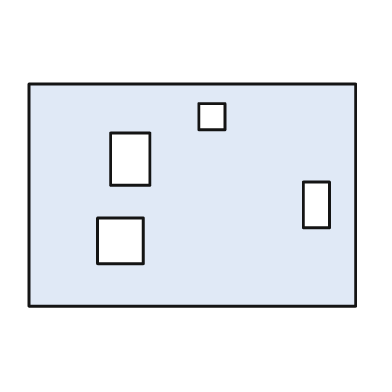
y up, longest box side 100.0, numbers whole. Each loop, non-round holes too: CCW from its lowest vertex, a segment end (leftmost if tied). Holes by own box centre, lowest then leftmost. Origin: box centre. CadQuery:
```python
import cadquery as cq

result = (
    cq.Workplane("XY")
    .moveTo(-50.0, -34.0)
    .lineTo(50.0, -34.0)
    .lineTo(50.0, 34.0)
    .lineTo(-50.0, 34.0)
    .close()
    .moveTo(-29.0, -21.0)
    .lineTo(-15.0, -21.0)
    .lineTo(-15.0, -7.0)
    .lineTo(-29.0, -7.0)
    .close()
    .moveTo(34.0, -10.0)
    .lineTo(42.0, -10.0)
    .lineTo(42.0, 4.0)
    .lineTo(34.0, 4.0)
    .close()
    .moveTo(-25.0, 3.0)
    .lineTo(-13.0, 3.0)
    .lineTo(-13.0, 19.0)
    .lineTo(-25.0, 19.0)
    .close()
    .moveTo(2.0, 20.0)
    .lineTo(10.0, 20.0)
    .lineTo(10.0, 28.0)
    .lineTo(2.0, 28.0)
    .close()
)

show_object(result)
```